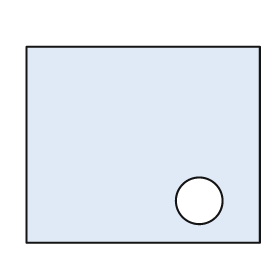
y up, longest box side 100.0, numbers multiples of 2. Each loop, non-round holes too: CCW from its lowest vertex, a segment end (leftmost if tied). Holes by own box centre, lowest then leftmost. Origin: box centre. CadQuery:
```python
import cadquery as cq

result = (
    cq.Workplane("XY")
    .moveTo(-50.0, -42.0)
    .lineTo(50.0, -42.0)
    .lineTo(50.0, 42.0)
    .lineTo(-50.0, 42.0)
    .close()
    .moveTo(24.0, -24.0)
    .circle(10.0)
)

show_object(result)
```